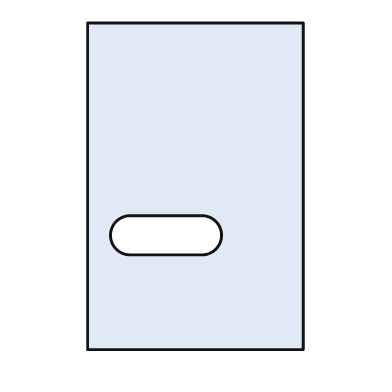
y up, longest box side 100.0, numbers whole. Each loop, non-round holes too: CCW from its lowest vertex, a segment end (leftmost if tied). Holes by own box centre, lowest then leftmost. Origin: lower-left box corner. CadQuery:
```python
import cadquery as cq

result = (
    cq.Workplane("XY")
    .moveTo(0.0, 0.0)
    .lineTo(66.0, 0.0)
    .lineTo(66.0, 100.0)
    .lineTo(0.0, 100.0)
    .close()
    .moveTo(13.0, 29.0)
    .lineTo(35.0, 29.0)
    .threePointArc((41.0, 35.0), (35.0, 41.0))
    .lineTo(13.0, 41.0)
    .threePointArc((7.0, 35.0), (13.0, 29.0))
    .close()
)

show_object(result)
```